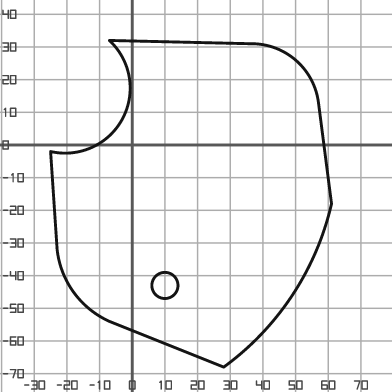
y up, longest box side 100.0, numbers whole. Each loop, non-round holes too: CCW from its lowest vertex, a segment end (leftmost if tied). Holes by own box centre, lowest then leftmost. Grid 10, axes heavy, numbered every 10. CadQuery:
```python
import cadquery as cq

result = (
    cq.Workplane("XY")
    .moveTo(28.0, -68.0)
    .threePointArc((49.0, -46.0), (61.0, -18.0))
    .lineTo(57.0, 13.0)
    .threePointArc((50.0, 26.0), (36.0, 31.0))
    .lineTo(-7.0, 32.0)
    .threePointArc((-3.0, 8.0), (-25.0, -2.0))
    .lineTo(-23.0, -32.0)
    .threePointArc((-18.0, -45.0), (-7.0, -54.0))
    .close()
    .moveTo(10.0, -43.0)
    .circle(4.0)
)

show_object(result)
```